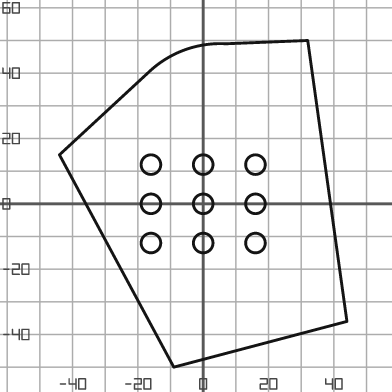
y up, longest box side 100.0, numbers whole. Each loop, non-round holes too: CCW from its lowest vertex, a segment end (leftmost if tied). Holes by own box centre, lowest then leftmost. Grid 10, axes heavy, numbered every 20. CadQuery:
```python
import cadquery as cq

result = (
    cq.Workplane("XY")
    .moveTo(-9.0, -50.0)
    .lineTo(44.0, -36.0)
    .lineTo(32.0, 50.0)
    .lineTo(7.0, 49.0)
    .threePointArc((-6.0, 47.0), (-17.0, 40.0))
    .lineTo(-44.0, 15.0)
    .close()
    .moveTo(-16.0, -12.0)
    .circle(3.0)
    .moveTo(0.0, -12.0)
    .circle(3.0)
    .moveTo(16.0, -12.0)
    .circle(3.0)
    .moveTo(-16.0, 0.0)
    .circle(3.0)
    .moveTo(0.0, 0.0)
    .circle(3.0)
    .moveTo(16.0, 0.0)
    .circle(3.0)
    .moveTo(-16.0, 12.0)
    .circle(3.0)
    .moveTo(0.0, 12.0)
    .circle(3.0)
    .moveTo(16.0, 12.0)
    .circle(3.0)
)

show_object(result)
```